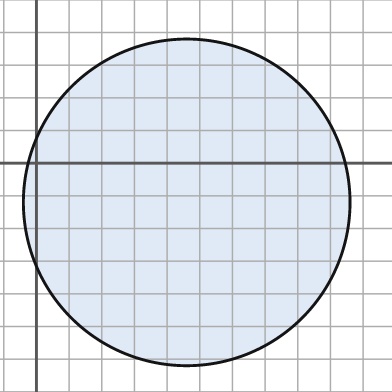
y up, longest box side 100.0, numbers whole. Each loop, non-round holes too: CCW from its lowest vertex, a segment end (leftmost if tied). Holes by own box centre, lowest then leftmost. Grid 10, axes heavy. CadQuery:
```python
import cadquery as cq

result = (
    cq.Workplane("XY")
    .moveTo(46.0, -12.0)
    .circle(50.0)
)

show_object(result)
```